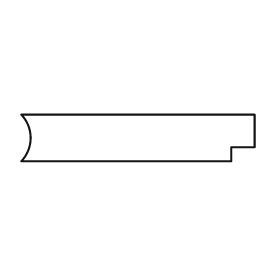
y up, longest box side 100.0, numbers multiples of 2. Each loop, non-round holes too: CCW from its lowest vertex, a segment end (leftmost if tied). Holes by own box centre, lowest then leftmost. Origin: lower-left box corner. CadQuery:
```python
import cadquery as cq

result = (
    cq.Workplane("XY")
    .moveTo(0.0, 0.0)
    .lineTo(90.0, 0.0)
    .lineTo(90.0, 6.0)
    .lineTo(100.0, 6.0)
    .lineTo(100.0, 20.0)
    .lineTo(0.0, 20.0)
    .threePointArc((4.0, 10.0), (0.0, 0.0))
    .close()
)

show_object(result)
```